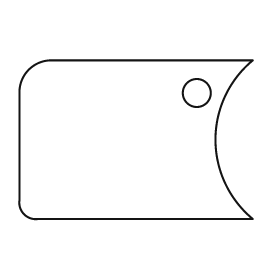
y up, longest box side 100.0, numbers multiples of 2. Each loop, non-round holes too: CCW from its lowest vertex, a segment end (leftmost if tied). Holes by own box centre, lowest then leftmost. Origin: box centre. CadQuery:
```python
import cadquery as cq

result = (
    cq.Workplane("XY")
    .moveTo(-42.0, -34.0)
    .lineTo(50.0, -34.0)
    .threePointArc((34.0, 0.0), (50.0, 34.0))
    .lineTo(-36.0, 34.0)
    .threePointArc((-46.0, 30.0), (-50.0, 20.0))
    .lineTo(-50.0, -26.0)
    .threePointArc((-48.0, -32.0), (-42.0, -34.0))
    .close()
    .moveTo(26.0, 20.0)
    .circle(6.0)
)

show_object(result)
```